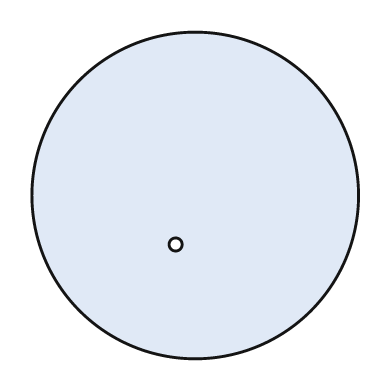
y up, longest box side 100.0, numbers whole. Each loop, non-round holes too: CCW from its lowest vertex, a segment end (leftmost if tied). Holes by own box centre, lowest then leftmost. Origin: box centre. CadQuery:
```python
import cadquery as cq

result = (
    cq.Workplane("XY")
    .moveTo(0.0, 0.0)
    .circle(50.0)
    .moveTo(-6.0, -15.0)
    .circle(2.0)
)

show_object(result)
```